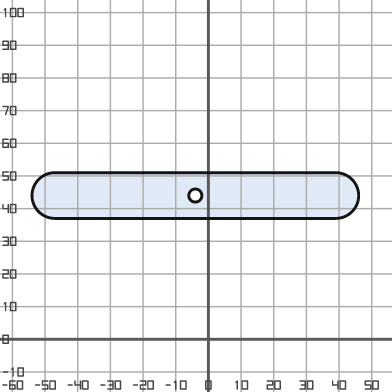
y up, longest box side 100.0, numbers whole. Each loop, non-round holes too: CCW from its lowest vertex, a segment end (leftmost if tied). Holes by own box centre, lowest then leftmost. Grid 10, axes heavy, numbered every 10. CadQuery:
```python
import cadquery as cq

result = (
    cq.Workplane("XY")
    .moveTo(-47.0, 37.0)
    .lineTo(39.0, 37.0)
    .threePointArc((46.0, 44.0), (39.0, 51.0))
    .lineTo(-47.0, 51.0)
    .threePointArc((-54.0, 44.0), (-47.0, 37.0))
    .close()
    .moveTo(-4.0, 44.0)
    .circle(2.0)
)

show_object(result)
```